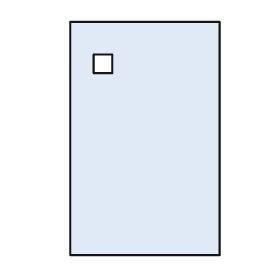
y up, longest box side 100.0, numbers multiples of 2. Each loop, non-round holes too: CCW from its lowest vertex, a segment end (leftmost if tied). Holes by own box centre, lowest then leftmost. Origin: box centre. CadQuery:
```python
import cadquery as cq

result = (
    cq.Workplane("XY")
    .moveTo(-32.0, -50.0)
    .lineTo(32.0, -50.0)
    .lineTo(32.0, 50.0)
    .lineTo(-32.0, 50.0)
    .close()
    .moveTo(-22.0, 28.0)
    .lineTo(-14.0, 28.0)
    .lineTo(-14.0, 36.0)
    .lineTo(-22.0, 36.0)
    .close()
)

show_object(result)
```